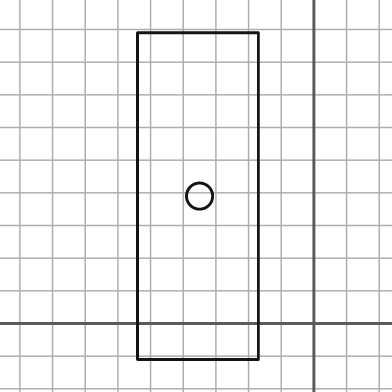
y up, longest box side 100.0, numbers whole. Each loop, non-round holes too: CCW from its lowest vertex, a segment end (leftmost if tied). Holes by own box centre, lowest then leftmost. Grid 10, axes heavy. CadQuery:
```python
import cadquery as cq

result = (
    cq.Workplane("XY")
    .moveTo(-54.0, -11.0)
    .lineTo(-17.0, -11.0)
    .lineTo(-17.0, 89.0)
    .lineTo(-54.0, 89.0)
    .close()
    .moveTo(-35.0, 39.0)
    .circle(4.0)
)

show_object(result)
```